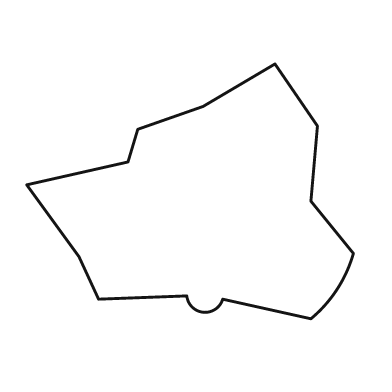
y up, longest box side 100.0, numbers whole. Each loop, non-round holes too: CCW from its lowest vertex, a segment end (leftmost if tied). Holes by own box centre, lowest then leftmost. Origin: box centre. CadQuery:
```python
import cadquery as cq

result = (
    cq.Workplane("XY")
    .moveTo(37.0, -39.0)
    .threePointArc((45.0, -30.0), (50.0, -19.0))
    .lineTo(37.0, -3.0)
    .lineTo(39.0, 20.0)
    .lineTo(26.0, 39.0)
    .lineTo(4.0, 26.0)
    .lineTo(-16.0, 19.0)
    .lineTo(-19.0, 9.0)
    .lineTo(-50.0, 2.0)
    .lineTo(-34.0, -20.0)
    .lineTo(-28.0, -33.0)
    .lineTo(-1.0, -32.0)
    .threePointArc((4.0, -37.0), (10.0, -33.0))
    .close()
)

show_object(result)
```